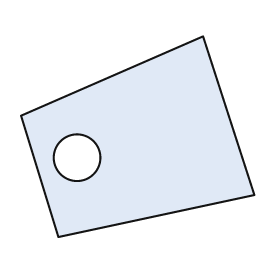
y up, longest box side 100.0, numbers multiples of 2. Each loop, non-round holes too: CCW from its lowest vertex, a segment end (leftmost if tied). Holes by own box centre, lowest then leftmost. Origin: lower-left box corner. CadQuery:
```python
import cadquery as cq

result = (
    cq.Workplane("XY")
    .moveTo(16.0, 0.0)
    .lineTo(100.0, 18.0)
    .lineTo(78.0, 86.0)
    .lineTo(0.0, 52.0)
    .close()
    .moveTo(24.0, 34.0)
    .circle(10.0)
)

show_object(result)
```